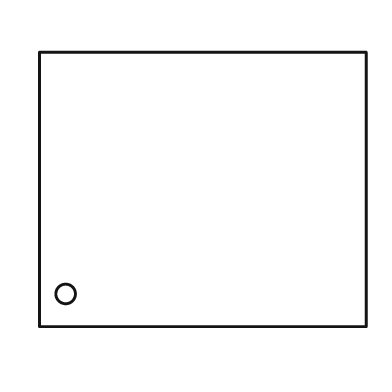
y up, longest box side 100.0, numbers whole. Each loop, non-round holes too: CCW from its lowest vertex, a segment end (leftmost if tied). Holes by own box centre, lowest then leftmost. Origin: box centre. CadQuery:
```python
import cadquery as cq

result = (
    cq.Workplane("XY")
    .moveTo(-50.0, -42.0)
    .lineTo(50.0, -42.0)
    .lineTo(50.0, 42.0)
    .lineTo(-50.0, 42.0)
    .close()
    .moveTo(-42.0, -32.0)
    .circle(3.0)
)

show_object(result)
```